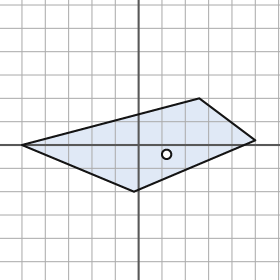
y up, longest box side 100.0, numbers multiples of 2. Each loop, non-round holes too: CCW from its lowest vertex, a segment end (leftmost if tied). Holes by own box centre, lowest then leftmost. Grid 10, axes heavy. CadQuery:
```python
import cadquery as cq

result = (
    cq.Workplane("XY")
    .moveTo(-2.0, -20.0)
    .lineTo(50.0, 2.0)
    .lineTo(26.0, 20.0)
    .lineTo(-50.0, 0.0)
    .close()
    .moveTo(12.0, -4.0)
    .circle(2.0)
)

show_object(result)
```